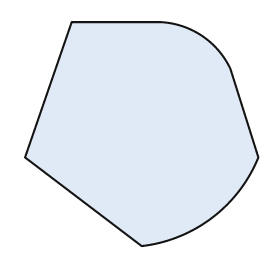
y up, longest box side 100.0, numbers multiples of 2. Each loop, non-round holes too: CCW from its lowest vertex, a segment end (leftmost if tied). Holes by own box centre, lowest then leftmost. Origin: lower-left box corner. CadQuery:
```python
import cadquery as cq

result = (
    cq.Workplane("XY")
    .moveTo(50.0, 0.0)
    .threePointArc((80.0, 12.0), (100.0, 38.0))
    .lineTo(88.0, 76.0)
    .threePointArc((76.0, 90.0), (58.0, 96.0))
    .lineTo(20.0, 96.0)
    .lineTo(0.0, 38.0)
    .close()
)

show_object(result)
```